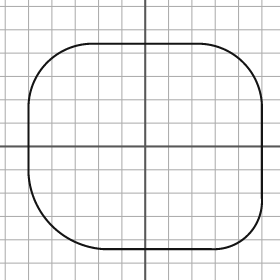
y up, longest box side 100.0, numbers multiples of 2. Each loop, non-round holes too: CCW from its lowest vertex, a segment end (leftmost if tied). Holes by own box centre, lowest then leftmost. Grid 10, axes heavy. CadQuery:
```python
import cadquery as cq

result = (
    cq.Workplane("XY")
    .moveTo(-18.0, -44.0)
    .lineTo(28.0, -44.0)
    .threePointArc((44.0, -38.0), (50.0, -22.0))
    .lineTo(50.0, 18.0)
    .threePointArc((42.0, 36.0), (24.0, 44.0))
    .lineTo(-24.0, 44.0)
    .threePointArc((-42.0, 36.0), (-50.0, 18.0))
    .lineTo(-50.0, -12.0)
    .threePointArc((-40.0, -34.0), (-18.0, -44.0))
    .close()
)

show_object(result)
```